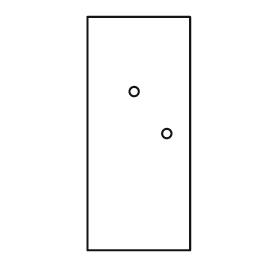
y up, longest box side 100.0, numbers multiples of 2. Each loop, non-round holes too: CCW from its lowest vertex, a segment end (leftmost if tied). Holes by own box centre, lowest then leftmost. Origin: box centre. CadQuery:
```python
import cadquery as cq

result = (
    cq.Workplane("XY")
    .moveTo(-22.0, -50.0)
    .lineTo(22.0, -50.0)
    .lineTo(22.0, 50.0)
    .lineTo(-22.0, 50.0)
    .close()
    .moveTo(12.0, 0.0)
    .circle(2.0)
    .moveTo(-2.0, 18.0)
    .circle(2.0)
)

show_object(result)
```